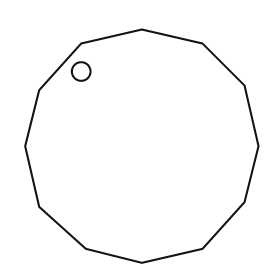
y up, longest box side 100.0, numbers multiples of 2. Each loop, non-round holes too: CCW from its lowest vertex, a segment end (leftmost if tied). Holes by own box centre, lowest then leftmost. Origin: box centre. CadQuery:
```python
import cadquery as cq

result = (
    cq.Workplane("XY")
    .moveTo(0.0, -50.0)
    .lineTo(26.0, -44.0)
    .lineTo(44.0, -24.0)
    .lineTo(50.0, 0.0)
    .lineTo(44.0, 26.0)
    .lineTo(26.0, 44.0)
    .lineTo(0.0, 50.0)
    .lineTo(-26.0, 44.0)
    .lineTo(-44.0, 24.0)
    .lineTo(-50.0, 0.0)
    .lineTo(-44.0, -26.0)
    .lineTo(-24.0, -44.0)
    .close()
    .moveTo(-26.0, 32.0)
    .circle(4.0)
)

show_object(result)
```